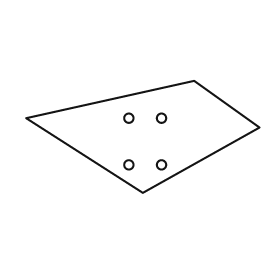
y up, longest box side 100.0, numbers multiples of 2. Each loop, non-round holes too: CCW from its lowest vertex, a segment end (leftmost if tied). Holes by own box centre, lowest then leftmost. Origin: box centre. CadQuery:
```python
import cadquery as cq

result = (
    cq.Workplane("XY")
    .moveTo(0.0, -24.0)
    .lineTo(50.0, 4.0)
    .lineTo(22.0, 24.0)
    .lineTo(-50.0, 8.0)
    .close()
    .moveTo(-6.0, -12.0)
    .circle(2.0)
    .moveTo(8.0, -12.0)
    .circle(2.0)
    .moveTo(-6.0, 8.0)
    .circle(2.0)
    .moveTo(8.0, 8.0)
    .circle(2.0)
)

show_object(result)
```